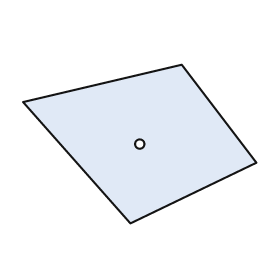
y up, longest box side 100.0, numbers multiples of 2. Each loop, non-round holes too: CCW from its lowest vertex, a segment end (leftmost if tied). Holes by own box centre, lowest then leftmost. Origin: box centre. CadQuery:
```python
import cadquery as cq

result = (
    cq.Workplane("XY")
    .moveTo(-4.0, -34.0)
    .lineTo(50.0, -8.0)
    .lineTo(18.0, 34.0)
    .lineTo(-50.0, 18.0)
    .close()
    .moveTo(0.0, 0.0)
    .circle(2.0)
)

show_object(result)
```